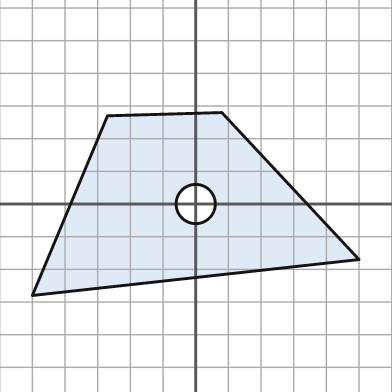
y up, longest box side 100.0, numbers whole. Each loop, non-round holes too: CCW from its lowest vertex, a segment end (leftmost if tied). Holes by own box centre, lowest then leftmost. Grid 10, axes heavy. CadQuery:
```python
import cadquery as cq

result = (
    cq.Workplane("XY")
    .moveTo(-50.0, -28.0)
    .lineTo(50.0, -17.0)
    .lineTo(8.0, 28.0)
    .lineTo(-27.0, 27.0)
    .close()
    .moveTo(0.0, 0.0)
    .circle(6.0)
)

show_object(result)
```